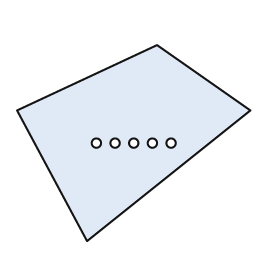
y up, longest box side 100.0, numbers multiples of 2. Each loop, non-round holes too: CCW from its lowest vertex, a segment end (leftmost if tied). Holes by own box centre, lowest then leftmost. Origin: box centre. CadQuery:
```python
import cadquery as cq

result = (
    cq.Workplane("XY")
    .moveTo(-20.0, -42.0)
    .lineTo(50.0, 14.0)
    .lineTo(10.0, 42.0)
    .lineTo(-50.0, 14.0)
    .close()
    .moveTo(-16.0, 0.0)
    .circle(2.0)
    .moveTo(-8.0, 0.0)
    .circle(2.0)
    .moveTo(0.0, 0.0)
    .circle(2.0)
    .moveTo(8.0, 0.0)
    .circle(2.0)
    .moveTo(16.0, 0.0)
    .circle(2.0)
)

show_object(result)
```